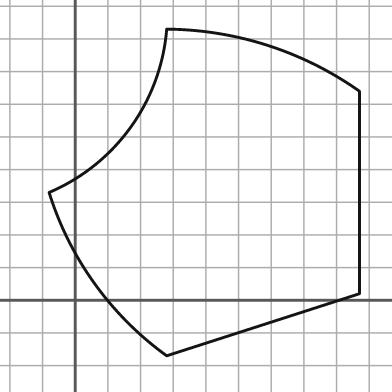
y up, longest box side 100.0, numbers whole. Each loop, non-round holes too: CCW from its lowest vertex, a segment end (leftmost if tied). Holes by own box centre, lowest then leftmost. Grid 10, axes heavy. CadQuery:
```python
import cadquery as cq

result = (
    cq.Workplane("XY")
    .moveTo(28.0, -17.0)
    .lineTo(87.0, 2.0)
    .lineTo(87.0, 64.0)
    .threePointArc((59.0, 78.0), (28.0, 83.0))
    .threePointArc((17.0, 53.0), (-8.0, 33.0))
    .threePointArc((6.0, 5.0), (28.0, -17.0))
    .close()
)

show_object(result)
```